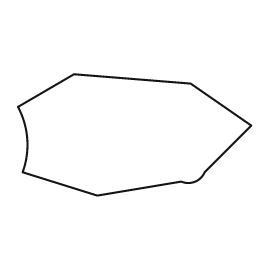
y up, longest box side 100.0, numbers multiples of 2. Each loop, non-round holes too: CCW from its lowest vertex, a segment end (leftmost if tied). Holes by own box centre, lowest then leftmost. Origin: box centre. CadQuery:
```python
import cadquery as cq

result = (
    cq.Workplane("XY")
    .moveTo(-16.0, -26.0)
    .lineTo(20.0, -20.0)
    .threePointArc((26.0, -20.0), (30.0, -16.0))
    .lineTo(50.0, 4.0)
    .lineTo(24.0, 22.0)
    .lineTo(-26.0, 26.0)
    .lineTo(-50.0, 12.0)
    .threePointArc((-46.0, -2.0), (-48.0, -16.0))
    .close()
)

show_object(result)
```